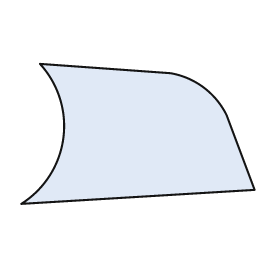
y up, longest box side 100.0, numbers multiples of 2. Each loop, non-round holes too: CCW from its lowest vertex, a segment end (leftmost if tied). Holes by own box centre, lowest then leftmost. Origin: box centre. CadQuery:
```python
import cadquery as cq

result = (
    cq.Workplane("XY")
    .moveTo(-50.0, -30.0)
    .lineTo(50.0, -24.0)
    .lineTo(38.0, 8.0)
    .threePointArc((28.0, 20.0), (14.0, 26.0))
    .lineTo(-42.0, 30.0)
    .threePointArc((-32.0, -2.0), (-50.0, -30.0))
    .close()
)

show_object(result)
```